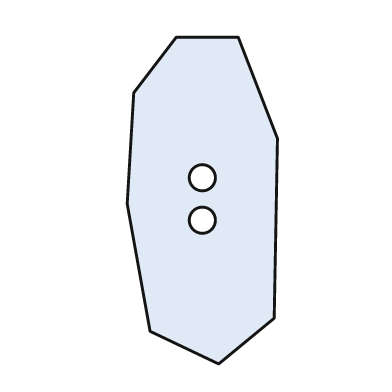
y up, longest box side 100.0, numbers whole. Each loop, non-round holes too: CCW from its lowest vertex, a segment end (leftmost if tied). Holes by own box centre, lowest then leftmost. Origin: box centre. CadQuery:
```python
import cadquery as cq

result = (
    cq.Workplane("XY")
    .moveTo(5.0, -50.0)
    .lineTo(22.0, -36.0)
    .lineTo(23.0, 19.0)
    .lineTo(11.0, 50.0)
    .lineTo(-8.0, 50.0)
    .lineTo(-21.0, 33.0)
    .lineTo(-23.0, -1.0)
    .lineTo(-16.0, -40.0)
    .close()
    .moveTo(0.0, -6.0)
    .circle(4.0)
    .moveTo(0.0, 7.0)
    .circle(4.0)
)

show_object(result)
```